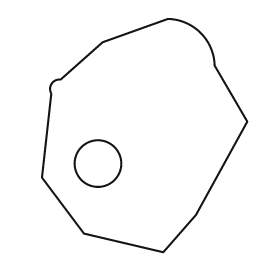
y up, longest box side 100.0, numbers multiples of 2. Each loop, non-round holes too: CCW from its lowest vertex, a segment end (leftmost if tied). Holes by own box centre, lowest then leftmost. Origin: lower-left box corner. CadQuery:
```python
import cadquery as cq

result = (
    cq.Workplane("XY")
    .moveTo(52.0, 0.0)
    .lineTo(66.0, 16.0)
    .lineTo(88.0, 56.0)
    .lineTo(74.0, 80.0)
    .threePointArc((68.0, 94.0), (54.0, 100.0))
    .lineTo(26.0, 90.0)
    .lineTo(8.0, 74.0)
    .threePointArc((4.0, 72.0), (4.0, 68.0))
    .lineTo(0.0, 32.0)
    .lineTo(18.0, 8.0)
    .close()
    .moveTo(24.0, 38.0)
    .circle(10.0)
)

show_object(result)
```